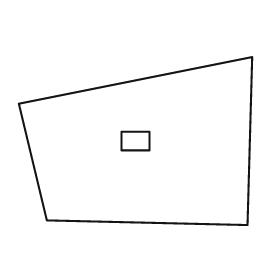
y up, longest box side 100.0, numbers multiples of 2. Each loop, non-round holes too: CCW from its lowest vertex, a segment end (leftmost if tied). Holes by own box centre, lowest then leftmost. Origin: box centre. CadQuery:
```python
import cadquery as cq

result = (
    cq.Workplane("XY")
    .moveTo(48.0, -36.0)
    .lineTo(50.0, 36.0)
    .lineTo(-50.0, 16.0)
    .lineTo(-38.0, -34.0)
    .close()
    .moveTo(-6.0, -4.0)
    .lineTo(6.0, -4.0)
    .lineTo(6.0, 4.0)
    .lineTo(-6.0, 4.0)
    .close()
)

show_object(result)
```